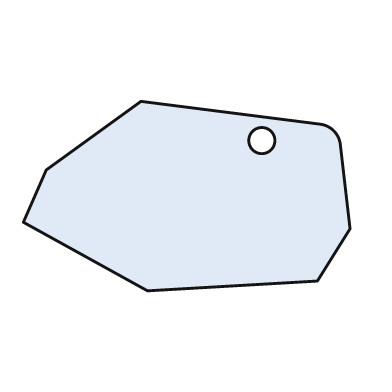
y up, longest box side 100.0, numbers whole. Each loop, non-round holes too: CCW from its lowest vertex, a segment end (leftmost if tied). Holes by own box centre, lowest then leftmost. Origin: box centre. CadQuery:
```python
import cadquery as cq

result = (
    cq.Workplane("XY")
    .moveTo(-12.0, -29.0)
    .lineTo(40.0, -26.0)
    .lineTo(50.0, -10.0)
    .lineTo(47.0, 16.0)
    .threePointArc((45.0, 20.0), (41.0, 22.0))
    .lineTo(-14.0, 29.0)
    .lineTo(-43.0, 8.0)
    .lineTo(-50.0, -8.0)
    .close()
    .moveTo(23.0, 17.0)
    .circle(4.0)
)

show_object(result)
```